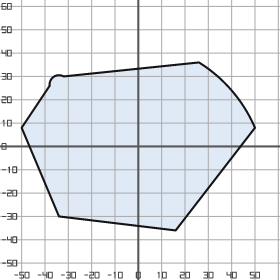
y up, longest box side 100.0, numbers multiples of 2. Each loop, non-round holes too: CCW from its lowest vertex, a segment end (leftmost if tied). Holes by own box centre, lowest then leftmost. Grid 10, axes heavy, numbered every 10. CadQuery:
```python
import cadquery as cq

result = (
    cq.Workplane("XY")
    .moveTo(16.0, -36.0)
    .lineTo(50.0, 8.0)
    .threePointArc((40.0, 24.0), (26.0, 36.0))
    .lineTo(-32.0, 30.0)
    .threePointArc((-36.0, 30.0), (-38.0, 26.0))
    .lineTo(-50.0, 8.0)
    .lineTo(-34.0, -30.0)
    .close()
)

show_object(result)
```